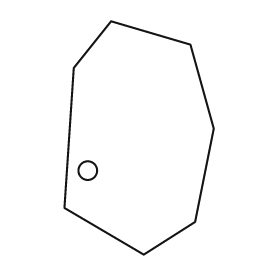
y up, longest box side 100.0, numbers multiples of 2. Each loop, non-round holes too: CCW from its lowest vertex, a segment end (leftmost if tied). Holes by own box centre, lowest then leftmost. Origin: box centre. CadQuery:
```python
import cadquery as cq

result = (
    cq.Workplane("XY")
    .moveTo(2.0, -50.0)
    .lineTo(24.0, -36.0)
    .lineTo(32.0, 4.0)
    .lineTo(22.0, 40.0)
    .lineTo(-12.0, 50.0)
    .lineTo(-28.0, 30.0)
    .lineTo(-32.0, -30.0)
    .close()
    .moveTo(-22.0, -14.0)
    .circle(4.0)
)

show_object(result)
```